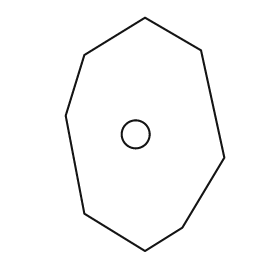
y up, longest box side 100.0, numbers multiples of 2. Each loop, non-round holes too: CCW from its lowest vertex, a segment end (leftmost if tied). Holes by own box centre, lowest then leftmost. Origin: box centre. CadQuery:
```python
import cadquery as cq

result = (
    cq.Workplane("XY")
    .moveTo(0.0, -50.0)
    .lineTo(16.0, -40.0)
    .lineTo(34.0, -10.0)
    .lineTo(24.0, 36.0)
    .lineTo(0.0, 50.0)
    .lineTo(-26.0, 34.0)
    .lineTo(-34.0, 8.0)
    .lineTo(-26.0, -34.0)
    .close()
    .moveTo(-4.0, 0.0)
    .circle(6.0)
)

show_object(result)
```